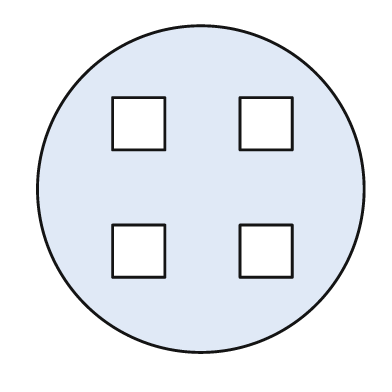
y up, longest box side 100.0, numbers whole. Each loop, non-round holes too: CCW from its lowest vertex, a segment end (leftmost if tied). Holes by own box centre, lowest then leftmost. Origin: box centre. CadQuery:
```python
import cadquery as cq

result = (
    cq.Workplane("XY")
    .moveTo(0.0, 0.0)
    .circle(50.0)
    .moveTo(-27.0, -27.0)
    .lineTo(-11.0, -27.0)
    .lineTo(-11.0, -11.0)
    .lineTo(-27.0, -11.0)
    .close()
    .moveTo(12.0, -27.0)
    .lineTo(28.0, -27.0)
    .lineTo(28.0, -11.0)
    .lineTo(12.0, -11.0)
    .close()
    .moveTo(-27.0, 12.0)
    .lineTo(-11.0, 12.0)
    .lineTo(-11.0, 28.0)
    .lineTo(-27.0, 28.0)
    .close()
    .moveTo(12.0, 12.0)
    .lineTo(28.0, 12.0)
    .lineTo(28.0, 28.0)
    .lineTo(12.0, 28.0)
    .close()
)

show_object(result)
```